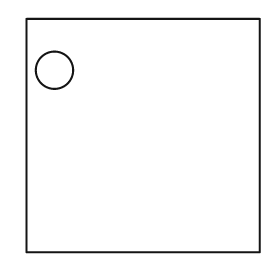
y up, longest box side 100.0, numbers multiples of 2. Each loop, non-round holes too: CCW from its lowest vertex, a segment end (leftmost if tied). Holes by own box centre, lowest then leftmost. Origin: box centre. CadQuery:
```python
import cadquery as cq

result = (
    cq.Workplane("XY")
    .moveTo(-50.0, -50.0)
    .lineTo(50.0, -50.0)
    .lineTo(50.0, 50.0)
    .lineTo(-50.0, 50.0)
    .close()
    .moveTo(-38.0, 28.0)
    .circle(8.0)
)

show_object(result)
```